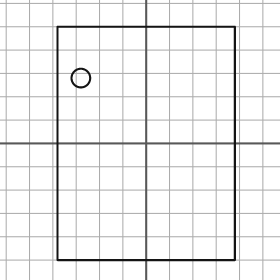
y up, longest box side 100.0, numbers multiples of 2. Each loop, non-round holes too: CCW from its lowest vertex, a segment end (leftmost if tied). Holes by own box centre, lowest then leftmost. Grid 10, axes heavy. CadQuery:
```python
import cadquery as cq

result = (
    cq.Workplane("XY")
    .moveTo(-38.0, -50.0)
    .lineTo(38.0, -50.0)
    .lineTo(38.0, 50.0)
    .lineTo(-38.0, 50.0)
    .close()
    .moveTo(-28.0, 28.0)
    .circle(4.0)
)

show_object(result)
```